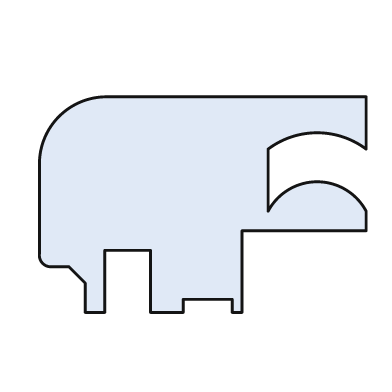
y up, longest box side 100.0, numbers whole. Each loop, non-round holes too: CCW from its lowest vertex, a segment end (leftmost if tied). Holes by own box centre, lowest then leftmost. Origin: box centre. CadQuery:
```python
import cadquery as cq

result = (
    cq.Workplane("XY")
    .moveTo(-36.0, -33.0)
    .lineTo(-30.0, -33.0)
    .lineTo(-30.0, -14.0)
    .lineTo(-16.0, -14.0)
    .lineTo(-16.0, -33.0)
    .lineTo(-6.0, -33.0)
    .lineTo(-6.0, -29.0)
    .lineTo(9.0, -29.0)
    .lineTo(9.0, -33.0)
    .lineTo(12.0, -33.0)
    .lineTo(12.0, -8.0)
    .lineTo(50.0, -8.0)
    .lineTo(50.0, -2.0)
    .threePointArc((35.0, 7.0), (20.0, -2.0))
    .lineTo(20.0, 17.0)
    .threePointArc((35.0, 22.0), (50.0, 17.0))
    .lineTo(50.0, 33.0)
    .lineTo(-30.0, 33.0)
    .threePointArc((-44.0, 27.0), (-50.0, 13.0))
    .lineTo(-50.0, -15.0)
    .threePointArc((-49.0, -18.0), (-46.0, -19.0))
    .lineTo(-41.0, -19.0)
    .lineTo(-36.0, -24.0)
    .close()
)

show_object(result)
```